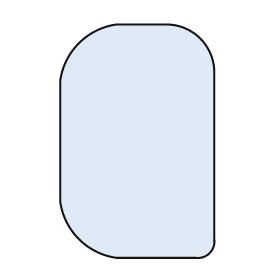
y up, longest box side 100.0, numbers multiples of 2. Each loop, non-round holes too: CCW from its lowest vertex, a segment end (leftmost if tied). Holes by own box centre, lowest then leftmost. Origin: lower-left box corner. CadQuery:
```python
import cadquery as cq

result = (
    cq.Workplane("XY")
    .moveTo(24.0, 0.0)
    .lineTo(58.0, 0.0)
    .threePointArc((64.0, 2.0), (66.0, 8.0))
    .lineTo(66.0, 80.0)
    .threePointArc((60.0, 94.0), (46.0, 100.0))
    .lineTo(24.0, 100.0)
    .threePointArc((8.0, 92.0), (0.0, 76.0))
    .lineTo(0.0, 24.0)
    .threePointArc((8.0, 8.0), (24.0, 0.0))
    .close()
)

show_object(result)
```